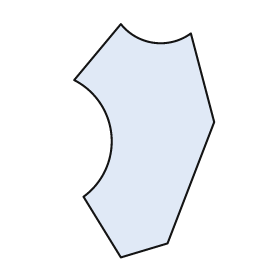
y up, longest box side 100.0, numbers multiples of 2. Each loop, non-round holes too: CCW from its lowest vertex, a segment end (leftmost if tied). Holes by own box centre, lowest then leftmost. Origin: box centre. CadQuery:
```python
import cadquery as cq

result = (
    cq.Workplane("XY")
    .moveTo(-10.0, -50.0)
    .lineTo(10.0, -44.0)
    .lineTo(30.0, 8.0)
    .lineTo(20.0, 46.0)
    .threePointArc((4.0, 42.0), (-10.0, 50.0))
    .lineTo(-30.0, 26.0)
    .threePointArc((-14.0, 2.0), (-26.0, -24.0))
    .close()
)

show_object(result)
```